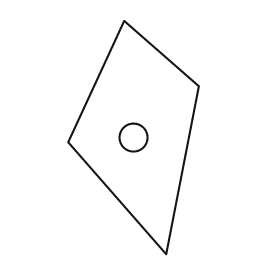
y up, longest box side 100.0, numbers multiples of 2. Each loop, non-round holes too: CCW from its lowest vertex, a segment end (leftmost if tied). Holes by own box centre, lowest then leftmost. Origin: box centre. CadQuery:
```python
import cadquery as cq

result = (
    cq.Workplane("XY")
    .moveTo(14.0, -50.0)
    .lineTo(28.0, 22.0)
    .lineTo(-4.0, 50.0)
    .lineTo(-28.0, -2.0)
    .close()
    .moveTo(0.0, 0.0)
    .circle(6.0)
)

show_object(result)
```